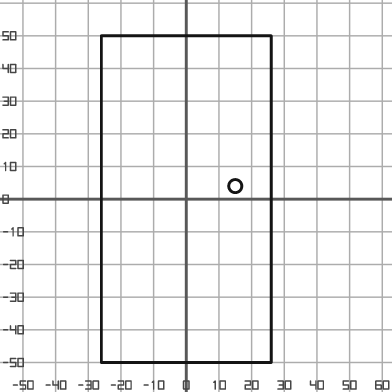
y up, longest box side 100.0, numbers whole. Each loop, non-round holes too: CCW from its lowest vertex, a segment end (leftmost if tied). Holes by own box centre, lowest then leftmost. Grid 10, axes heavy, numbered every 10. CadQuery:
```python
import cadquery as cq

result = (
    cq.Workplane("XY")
    .moveTo(-26.0, -50.0)
    .lineTo(26.0, -50.0)
    .lineTo(26.0, 50.0)
    .lineTo(-26.0, 50.0)
    .close()
    .moveTo(15.0, 4.0)
    .circle(2.0)
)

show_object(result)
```